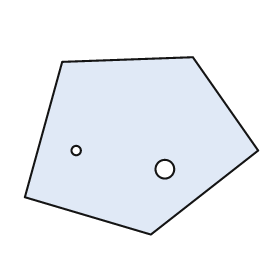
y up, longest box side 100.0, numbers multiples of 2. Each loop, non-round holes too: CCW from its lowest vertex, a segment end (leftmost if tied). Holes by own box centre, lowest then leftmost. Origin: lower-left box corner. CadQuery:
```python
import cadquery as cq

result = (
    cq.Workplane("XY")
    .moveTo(54.0, 0.0)
    .lineTo(100.0, 36.0)
    .lineTo(72.0, 76.0)
    .lineTo(16.0, 74.0)
    .lineTo(0.0, 16.0)
    .close()
    .moveTo(60.0, 28.0)
    .circle(4.0)
    .moveTo(22.0, 36.0)
    .circle(2.0)
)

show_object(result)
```